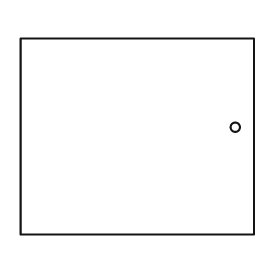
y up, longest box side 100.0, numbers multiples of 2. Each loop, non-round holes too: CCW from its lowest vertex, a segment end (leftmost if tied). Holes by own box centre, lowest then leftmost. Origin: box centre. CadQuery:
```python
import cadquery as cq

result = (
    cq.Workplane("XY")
    .moveTo(-50.0, -42.0)
    .lineTo(50.0, -42.0)
    .lineTo(50.0, 42.0)
    .lineTo(-50.0, 42.0)
    .close()
    .moveTo(42.0, 4.0)
    .circle(2.0)
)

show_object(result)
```